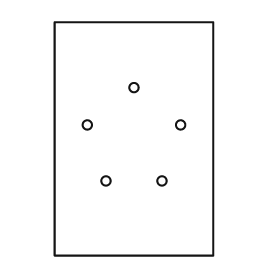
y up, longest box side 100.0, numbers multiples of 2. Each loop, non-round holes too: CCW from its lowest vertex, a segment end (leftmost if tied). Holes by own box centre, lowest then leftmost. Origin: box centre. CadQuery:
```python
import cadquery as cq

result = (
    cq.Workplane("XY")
    .moveTo(-34.0, -50.0)
    .lineTo(34.0, -50.0)
    .lineTo(34.0, 50.0)
    .lineTo(-34.0, 50.0)
    .close()
    .moveTo(-12.0, -18.0)
    .circle(2.0)
    .moveTo(12.0, -18.0)
    .circle(2.0)
    .moveTo(-20.0, 6.0)
    .circle(2.0)
    .moveTo(20.0, 6.0)
    .circle(2.0)
    .moveTo(0.0, 22.0)
    .circle(2.0)
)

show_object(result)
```